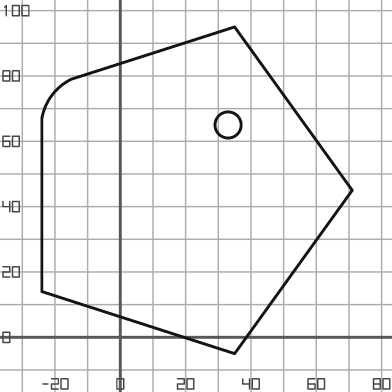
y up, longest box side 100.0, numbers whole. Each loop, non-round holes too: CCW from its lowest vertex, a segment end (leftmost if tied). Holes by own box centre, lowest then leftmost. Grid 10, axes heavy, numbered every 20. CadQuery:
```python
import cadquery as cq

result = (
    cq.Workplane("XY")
    .moveTo(35.0, -5.0)
    .lineTo(71.0, 45.0)
    .lineTo(35.0, 95.0)
    .lineTo(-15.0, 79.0)
    .threePointArc((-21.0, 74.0), (-24.0, 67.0))
    .lineTo(-24.0, 14.0)
    .close()
    .moveTo(33.0, 65.0)
    .circle(4.0)
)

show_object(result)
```